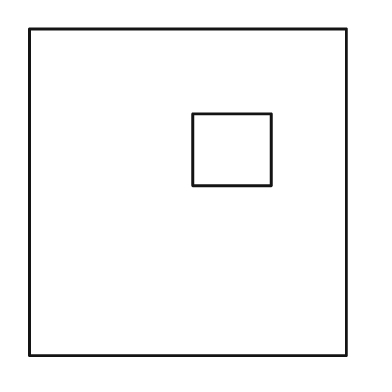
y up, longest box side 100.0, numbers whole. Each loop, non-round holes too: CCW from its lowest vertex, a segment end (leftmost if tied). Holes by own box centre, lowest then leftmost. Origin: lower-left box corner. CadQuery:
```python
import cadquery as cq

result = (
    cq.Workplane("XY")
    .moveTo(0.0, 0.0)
    .lineTo(97.0, 0.0)
    .lineTo(97.0, 100.0)
    .lineTo(0.0, 100.0)
    .close()
    .moveTo(50.0, 52.0)
    .lineTo(74.0, 52.0)
    .lineTo(74.0, 74.0)
    .lineTo(50.0, 74.0)
    .close()
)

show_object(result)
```